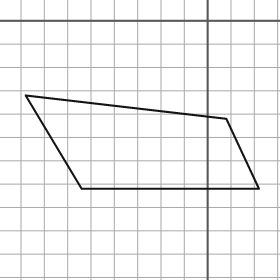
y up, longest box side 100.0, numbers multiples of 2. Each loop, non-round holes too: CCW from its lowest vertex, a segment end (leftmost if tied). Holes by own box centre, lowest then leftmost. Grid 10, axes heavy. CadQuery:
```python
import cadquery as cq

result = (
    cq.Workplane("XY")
    .moveTo(-54.0, -72.0)
    .lineTo(22.0, -72.0)
    .lineTo(8.0, -42.0)
    .lineTo(-78.0, -32.0)
    .close()
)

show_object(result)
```